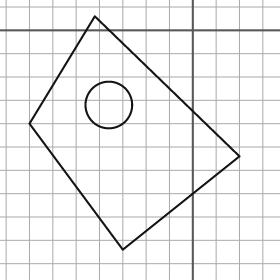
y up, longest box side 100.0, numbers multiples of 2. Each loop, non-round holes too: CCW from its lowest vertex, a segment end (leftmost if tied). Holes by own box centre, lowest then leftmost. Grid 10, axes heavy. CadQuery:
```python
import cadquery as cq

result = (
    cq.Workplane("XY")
    .moveTo(-30.0, -94.0)
    .lineTo(20.0, -54.0)
    .lineTo(-42.0, 6.0)
    .lineTo(-70.0, -40.0)
    .close()
    .moveTo(-36.0, -32.0)
    .circle(10.0)
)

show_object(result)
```